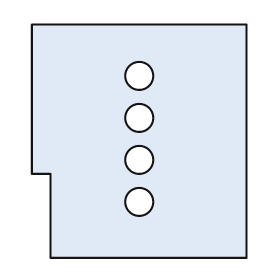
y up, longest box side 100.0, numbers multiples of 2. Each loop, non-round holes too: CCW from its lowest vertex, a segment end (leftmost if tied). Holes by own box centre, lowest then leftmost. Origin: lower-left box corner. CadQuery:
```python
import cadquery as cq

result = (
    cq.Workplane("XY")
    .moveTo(8.0, 0.0)
    .lineTo(92.0, 0.0)
    .lineTo(92.0, 100.0)
    .lineTo(0.0, 100.0)
    .lineTo(0.0, 36.0)
    .lineTo(8.0, 36.0)
    .close()
    .moveTo(46.0, 24.0)
    .circle(6.0)
    .moveTo(46.0, 42.0)
    .circle(6.0)
    .moveTo(46.0, 60.0)
    .circle(6.0)
    .moveTo(46.0, 78.0)
    .circle(6.0)
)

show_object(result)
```